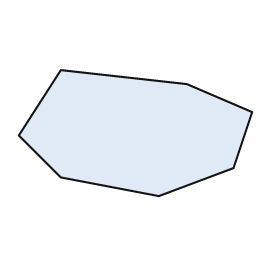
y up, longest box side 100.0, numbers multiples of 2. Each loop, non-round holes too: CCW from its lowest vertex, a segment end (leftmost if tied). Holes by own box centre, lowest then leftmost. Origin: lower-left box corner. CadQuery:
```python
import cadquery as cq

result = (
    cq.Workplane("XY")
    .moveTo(60.0, 0.0)
    .lineTo(92.0, 12.0)
    .lineTo(100.0, 36.0)
    .lineTo(72.0, 48.0)
    .lineTo(18.0, 54.0)
    .lineTo(0.0, 26.0)
    .lineTo(18.0, 8.0)
    .close()
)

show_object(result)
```